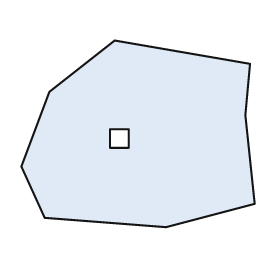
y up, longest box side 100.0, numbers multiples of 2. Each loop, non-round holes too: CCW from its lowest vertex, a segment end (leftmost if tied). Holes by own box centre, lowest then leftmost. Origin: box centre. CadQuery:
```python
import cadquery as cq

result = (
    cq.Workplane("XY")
    .moveTo(12.0, -40.0)
    .lineTo(50.0, -30.0)
    .lineTo(46.0, 8.0)
    .lineTo(48.0, 30.0)
    .lineTo(-10.0, 40.0)
    .lineTo(-38.0, 18.0)
    .lineTo(-50.0, -14.0)
    .lineTo(-40.0, -36.0)
    .close()
    .moveTo(-12.0, -6.0)
    .lineTo(-4.0, -6.0)
    .lineTo(-4.0, 2.0)
    .lineTo(-12.0, 2.0)
    .close()
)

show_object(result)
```